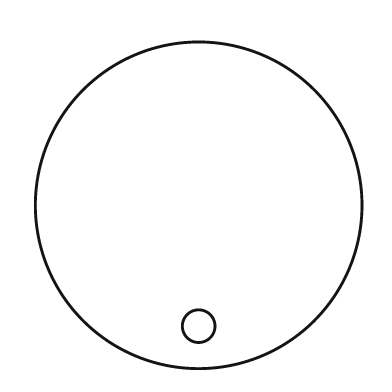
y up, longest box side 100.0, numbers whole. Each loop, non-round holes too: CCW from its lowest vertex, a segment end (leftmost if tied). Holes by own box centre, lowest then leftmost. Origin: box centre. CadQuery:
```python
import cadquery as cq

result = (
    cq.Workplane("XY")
    .moveTo(0.0, 0.0)
    .circle(50.0)
    .moveTo(0.0, -37.0)
    .circle(5.0)
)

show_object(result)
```